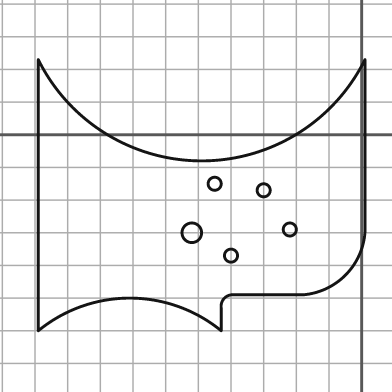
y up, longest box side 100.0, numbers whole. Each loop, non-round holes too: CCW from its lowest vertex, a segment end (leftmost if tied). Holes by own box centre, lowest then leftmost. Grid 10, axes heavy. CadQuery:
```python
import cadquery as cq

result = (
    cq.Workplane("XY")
    .moveTo(-99.0, -60.0)
    .threePointArc((-71.0, -50.0), (-43.0, -60.0))
    .lineTo(-43.0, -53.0)
    .threePointArc((-42.0, -50.0), (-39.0, -49.0))
    .lineTo(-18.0, -49.0)
    .threePointArc((-5.0, -43.0), (1.0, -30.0))
    .lineTo(1.0, 23.0)
    .threePointArc((-49.0, -8.0), (-99.0, 23.0))
    .close()
    .moveTo(-40.0, -37.0)
    .circle(2.0)
    .moveTo(-52.0, -30.0)
    .circle(3.0)
    .moveTo(-22.0, -29.0)
    .circle(2.0)
    .moveTo(-30.0, -17.0)
    .circle(2.0)
    .moveTo(-45.0, -15.0)
    .circle(2.0)
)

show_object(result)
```